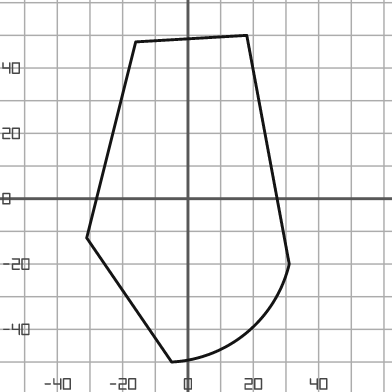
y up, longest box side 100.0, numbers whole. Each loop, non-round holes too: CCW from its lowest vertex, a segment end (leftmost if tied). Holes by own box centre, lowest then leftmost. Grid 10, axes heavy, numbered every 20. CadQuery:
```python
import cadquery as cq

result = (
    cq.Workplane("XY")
    .moveTo(-5.0, -50.0)
    .threePointArc((18.0, -41.0), (31.0, -20.0))
    .lineTo(18.0, 50.0)
    .lineTo(-16.0, 48.0)
    .lineTo(-31.0, -12.0)
    .close()
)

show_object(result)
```